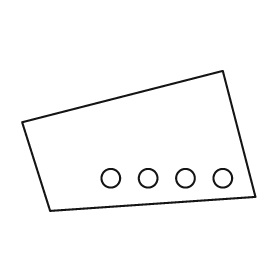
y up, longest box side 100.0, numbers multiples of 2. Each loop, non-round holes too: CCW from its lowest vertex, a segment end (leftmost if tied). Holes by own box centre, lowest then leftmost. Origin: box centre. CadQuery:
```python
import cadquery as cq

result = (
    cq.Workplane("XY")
    .moveTo(-38.0, -30.0)
    .lineTo(50.0, -24.0)
    .lineTo(36.0, 30.0)
    .lineTo(-50.0, 8.0)
    .close()
    .moveTo(-12.0, -16.0)
    .circle(4.0)
    .moveTo(4.0, -16.0)
    .circle(4.0)
    .moveTo(20.0, -16.0)
    .circle(4.0)
    .moveTo(36.0, -16.0)
    .circle(4.0)
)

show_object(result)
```